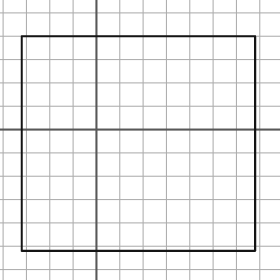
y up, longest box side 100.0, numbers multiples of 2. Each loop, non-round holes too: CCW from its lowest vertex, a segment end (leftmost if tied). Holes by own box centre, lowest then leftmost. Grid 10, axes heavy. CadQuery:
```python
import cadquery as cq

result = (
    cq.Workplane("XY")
    .moveTo(-32.0, -52.0)
    .lineTo(68.0, -52.0)
    .lineTo(68.0, 40.0)
    .lineTo(-32.0, 40.0)
    .close()
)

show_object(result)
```